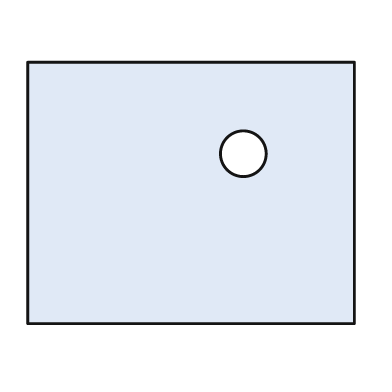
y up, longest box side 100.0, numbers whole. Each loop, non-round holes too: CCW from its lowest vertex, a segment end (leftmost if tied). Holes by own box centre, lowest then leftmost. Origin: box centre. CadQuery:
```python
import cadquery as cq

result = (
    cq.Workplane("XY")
    .moveTo(-50.0, -40.0)
    .lineTo(50.0, -40.0)
    .lineTo(50.0, 40.0)
    .lineTo(-50.0, 40.0)
    .close()
    .moveTo(16.0, 12.0)
    .circle(7.0)
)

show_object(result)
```